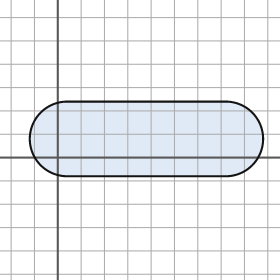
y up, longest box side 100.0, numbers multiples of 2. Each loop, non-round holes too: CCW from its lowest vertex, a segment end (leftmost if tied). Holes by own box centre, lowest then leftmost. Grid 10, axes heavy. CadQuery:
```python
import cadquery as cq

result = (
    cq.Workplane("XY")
    .moveTo(4.0, -8.0)
    .lineTo(72.0, -8.0)
    .threePointArc((88.0, 8.0), (72.0, 24.0))
    .lineTo(4.0, 24.0)
    .threePointArc((-12.0, 8.0), (4.0, -8.0))
    .close()
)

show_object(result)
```